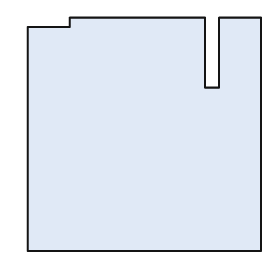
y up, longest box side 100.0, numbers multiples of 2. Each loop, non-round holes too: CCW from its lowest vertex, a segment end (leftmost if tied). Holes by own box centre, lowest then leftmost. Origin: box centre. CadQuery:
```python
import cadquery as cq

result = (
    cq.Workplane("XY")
    .moveTo(-50.0, -50.0)
    .lineTo(50.0, -50.0)
    .lineTo(50.0, 50.0)
    .lineTo(32.0, 50.0)
    .lineTo(32.0, 20.0)
    .lineTo(26.0, 20.0)
    .lineTo(26.0, 50.0)
    .lineTo(-32.0, 50.0)
    .lineTo(-32.0, 46.0)
    .lineTo(-50.0, 46.0)
    .close()
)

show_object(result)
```